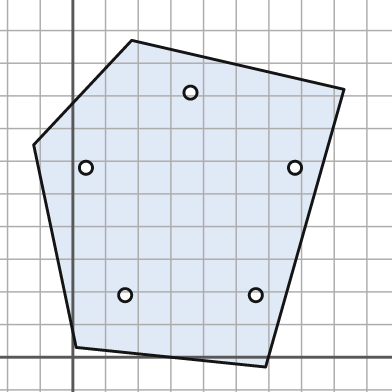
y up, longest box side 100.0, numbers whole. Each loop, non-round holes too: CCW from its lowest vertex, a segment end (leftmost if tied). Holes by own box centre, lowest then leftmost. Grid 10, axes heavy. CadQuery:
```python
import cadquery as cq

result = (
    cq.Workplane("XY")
    .moveTo(59.0, -3.0)
    .lineTo(83.0, 82.0)
    .lineTo(18.0, 97.0)
    .lineTo(-12.0, 65.0)
    .lineTo(1.0, 3.0)
    .close()
    .moveTo(16.0, 19.0)
    .circle(2.0)
    .moveTo(56.0, 19.0)
    .circle(2.0)
    .moveTo(4.0, 58.0)
    .circle(2.0)
    .moveTo(68.0, 58.0)
    .circle(2.0)
    .moveTo(36.0, 81.0)
    .circle(2.0)
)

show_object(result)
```